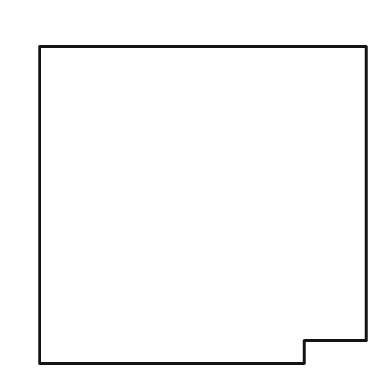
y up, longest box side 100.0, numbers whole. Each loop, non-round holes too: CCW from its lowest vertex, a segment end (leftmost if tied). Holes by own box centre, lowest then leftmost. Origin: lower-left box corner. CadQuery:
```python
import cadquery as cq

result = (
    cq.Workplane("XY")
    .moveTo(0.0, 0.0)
    .lineTo(81.0, 0.0)
    .lineTo(81.0, 7.0)
    .lineTo(100.0, 7.0)
    .lineTo(100.0, 97.0)
    .lineTo(0.0, 97.0)
    .close()
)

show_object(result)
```